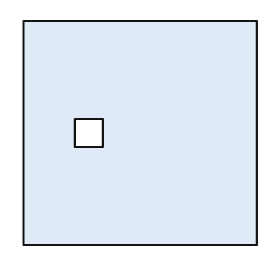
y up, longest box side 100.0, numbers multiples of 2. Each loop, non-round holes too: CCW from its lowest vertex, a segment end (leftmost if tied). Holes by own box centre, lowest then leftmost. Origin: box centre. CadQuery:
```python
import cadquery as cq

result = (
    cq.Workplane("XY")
    .moveTo(-50.0, -48.0)
    .lineTo(50.0, -48.0)
    .lineTo(50.0, 48.0)
    .lineTo(-50.0, 48.0)
    .close()
    .moveTo(-28.0, -6.0)
    .lineTo(-16.0, -6.0)
    .lineTo(-16.0, 6.0)
    .lineTo(-28.0, 6.0)
    .close()
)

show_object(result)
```